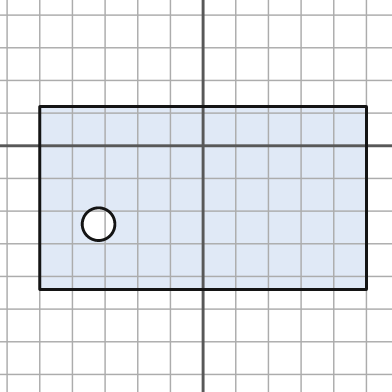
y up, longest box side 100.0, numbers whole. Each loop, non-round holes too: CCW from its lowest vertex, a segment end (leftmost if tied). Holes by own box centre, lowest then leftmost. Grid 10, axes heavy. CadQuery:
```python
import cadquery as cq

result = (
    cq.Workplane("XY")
    .moveTo(-50.0, -44.0)
    .lineTo(50.0, -44.0)
    .lineTo(50.0, 12.0)
    .lineTo(-50.0, 12.0)
    .close()
    .moveTo(-32.0, -24.0)
    .circle(5.0)
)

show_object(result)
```